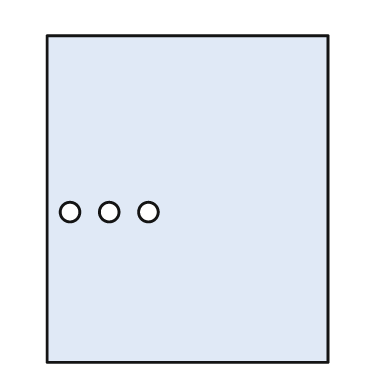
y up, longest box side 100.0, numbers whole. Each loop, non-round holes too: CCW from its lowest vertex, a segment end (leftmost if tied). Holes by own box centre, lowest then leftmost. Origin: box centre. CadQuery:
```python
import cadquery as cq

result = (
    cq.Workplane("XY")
    .moveTo(-43.0, -50.0)
    .lineTo(43.0, -50.0)
    .lineTo(43.0, 50.0)
    .lineTo(-43.0, 50.0)
    .close()
    .moveTo(-36.0, -4.0)
    .circle(3.0)
    .moveTo(-24.0, -4.0)
    .circle(3.0)
    .moveTo(-12.0, -4.0)
    .circle(3.0)
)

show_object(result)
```